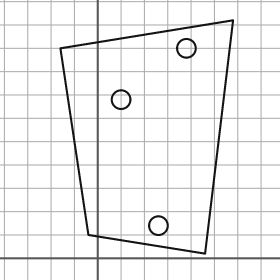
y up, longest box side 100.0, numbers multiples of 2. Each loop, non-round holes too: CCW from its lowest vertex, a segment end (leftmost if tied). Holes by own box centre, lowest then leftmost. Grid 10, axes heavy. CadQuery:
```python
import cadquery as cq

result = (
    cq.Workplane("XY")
    .moveTo(46.0, 2.0)
    .lineTo(58.0, 102.0)
    .lineTo(-16.0, 90.0)
    .lineTo(-4.0, 10.0)
    .close()
    .moveTo(26.0, 14.0)
    .circle(4.0)
    .moveTo(10.0, 68.0)
    .circle(4.0)
    .moveTo(38.0, 90.0)
    .circle(4.0)
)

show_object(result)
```